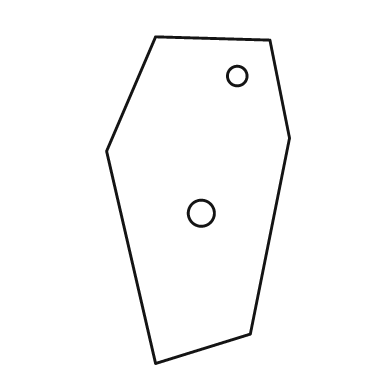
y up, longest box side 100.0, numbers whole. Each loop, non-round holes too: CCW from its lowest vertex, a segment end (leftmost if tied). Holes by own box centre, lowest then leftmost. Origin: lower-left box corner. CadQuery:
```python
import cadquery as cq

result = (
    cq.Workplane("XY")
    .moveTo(15.0, 0.0)
    .lineTo(44.0, 9.0)
    .lineTo(56.0, 69.0)
    .lineTo(50.0, 99.0)
    .lineTo(15.0, 100.0)
    .lineTo(0.0, 65.0)
    .close()
    .moveTo(29.0, 46.0)
    .circle(4.0)
    .moveTo(40.0, 88.0)
    .circle(3.0)
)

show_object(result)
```